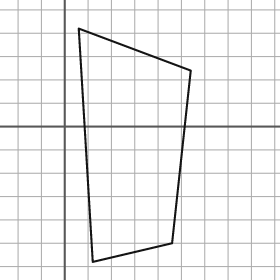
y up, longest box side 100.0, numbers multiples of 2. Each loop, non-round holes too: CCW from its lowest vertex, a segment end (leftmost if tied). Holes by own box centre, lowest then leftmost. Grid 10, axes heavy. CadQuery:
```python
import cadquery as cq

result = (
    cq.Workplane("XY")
    .moveTo(12.0, -58.0)
    .lineTo(46.0, -50.0)
    .lineTo(54.0, 24.0)
    .lineTo(6.0, 42.0)
    .close()
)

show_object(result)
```